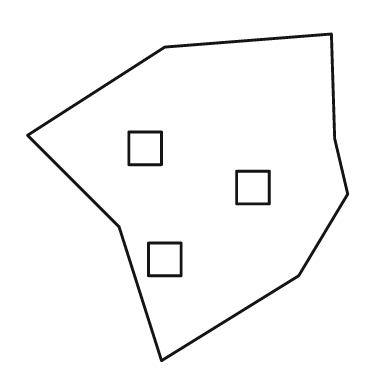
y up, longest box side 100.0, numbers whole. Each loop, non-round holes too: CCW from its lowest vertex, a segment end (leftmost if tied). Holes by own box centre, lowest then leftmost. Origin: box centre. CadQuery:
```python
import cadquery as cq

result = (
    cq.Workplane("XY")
    .moveTo(-8.0, -50.0)
    .lineTo(34.0, -24.0)
    .lineTo(49.0, 1.0)
    .lineTo(45.0, 18.0)
    .lineTo(44.0, 50.0)
    .lineTo(-7.0, 46.0)
    .lineTo(-49.0, 19.0)
    .lineTo(-21.0, -9.0)
    .close()
    .moveTo(-12.0, -24.0)
    .lineTo(-2.0, -24.0)
    .lineTo(-2.0, -14.0)
    .lineTo(-12.0, -14.0)
    .close()
    .moveTo(15.0, -2.0)
    .lineTo(25.0, -2.0)
    .lineTo(25.0, 8.0)
    .lineTo(15.0, 8.0)
    .close()
    .moveTo(-18.0, 10.0)
    .lineTo(-8.0, 10.0)
    .lineTo(-8.0, 20.0)
    .lineTo(-18.0, 20.0)
    .close()
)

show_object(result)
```